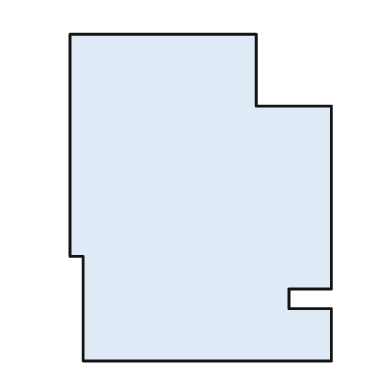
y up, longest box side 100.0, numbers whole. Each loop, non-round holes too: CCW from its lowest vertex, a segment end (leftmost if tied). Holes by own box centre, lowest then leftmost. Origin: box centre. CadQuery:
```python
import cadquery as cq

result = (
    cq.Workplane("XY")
    .moveTo(-36.0, -50.0)
    .lineTo(40.0, -50.0)
    .lineTo(40.0, -34.0)
    .lineTo(27.0, -34.0)
    .lineTo(27.0, -28.0)
    .lineTo(40.0, -28.0)
    .lineTo(40.0, 28.0)
    .lineTo(17.0, 28.0)
    .lineTo(17.0, 50.0)
    .lineTo(-40.0, 50.0)
    .lineTo(-40.0, -18.0)
    .lineTo(-36.0, -18.0)
    .close()
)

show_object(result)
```